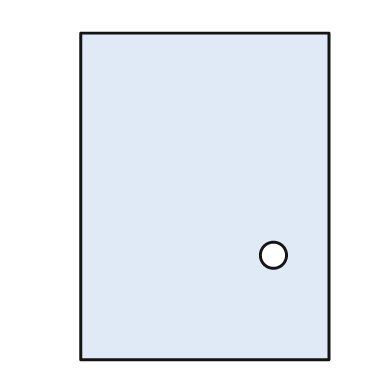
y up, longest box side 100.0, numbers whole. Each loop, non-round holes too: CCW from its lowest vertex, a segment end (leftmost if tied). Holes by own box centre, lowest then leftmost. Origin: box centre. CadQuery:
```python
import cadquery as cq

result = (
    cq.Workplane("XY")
    .moveTo(-38.0, -50.0)
    .lineTo(38.0, -50.0)
    .lineTo(38.0, 50.0)
    .lineTo(-38.0, 50.0)
    .close()
    .moveTo(21.0, -18.0)
    .circle(4.0)
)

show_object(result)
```